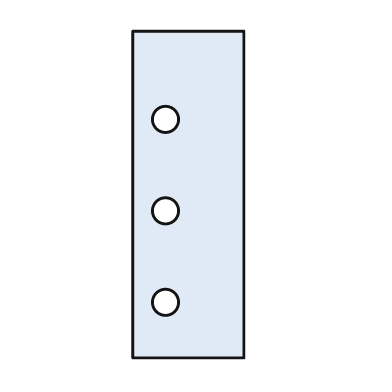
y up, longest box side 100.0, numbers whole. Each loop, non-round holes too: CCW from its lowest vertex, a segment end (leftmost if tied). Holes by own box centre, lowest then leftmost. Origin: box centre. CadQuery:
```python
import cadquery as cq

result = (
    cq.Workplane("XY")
    .moveTo(-17.0, -50.0)
    .lineTo(17.0, -50.0)
    .lineTo(17.0, 50.0)
    .lineTo(-17.0, 50.0)
    .close()
    .moveTo(-7.0, -33.0)
    .circle(4.0)
    .moveTo(-7.0, -5.0)
    .circle(4.0)
    .moveTo(-7.0, 23.0)
    .circle(4.0)
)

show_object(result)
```